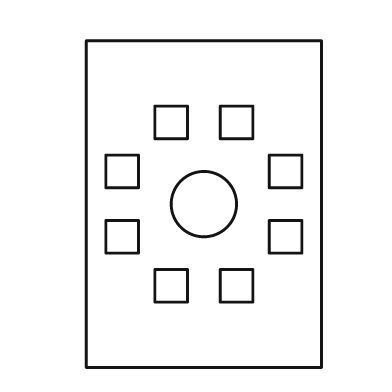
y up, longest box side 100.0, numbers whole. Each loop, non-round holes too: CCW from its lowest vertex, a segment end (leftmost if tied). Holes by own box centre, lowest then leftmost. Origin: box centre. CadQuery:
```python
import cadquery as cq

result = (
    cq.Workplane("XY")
    .moveTo(-36.0, -50.0)
    .lineTo(36.0, -50.0)
    .lineTo(36.0, 50.0)
    .lineTo(-36.0, 50.0)
    .close()
    .moveTo(-15.0, -30.0)
    .lineTo(-5.0, -30.0)
    .lineTo(-5.0, -20.0)
    .lineTo(-15.0, -20.0)
    .close()
    .moveTo(5.0, -30.0)
    .lineTo(15.0, -30.0)
    .lineTo(15.0, -20.0)
    .lineTo(5.0, -20.0)
    .close()
    .moveTo(-30.0, -15.0)
    .lineTo(-20.0, -15.0)
    .lineTo(-20.0, -5.0)
    .lineTo(-30.0, -5.0)
    .close()
    .moveTo(20.0, -15.0)
    .lineTo(30.0, -15.0)
    .lineTo(30.0, -5.0)
    .lineTo(20.0, -5.0)
    .close()
    .moveTo(0.0, 0.0)
    .circle(10.0)
    .moveTo(-30.0, 5.0)
    .lineTo(-20.0, 5.0)
    .lineTo(-20.0, 15.0)
    .lineTo(-30.0, 15.0)
    .close()
    .moveTo(20.0, 5.0)
    .lineTo(30.0, 5.0)
    .lineTo(30.0, 15.0)
    .lineTo(20.0, 15.0)
    .close()
    .moveTo(-15.0, 20.0)
    .lineTo(-5.0, 20.0)
    .lineTo(-5.0, 30.0)
    .lineTo(-15.0, 30.0)
    .close()
    .moveTo(5.0, 20.0)
    .lineTo(15.0, 20.0)
    .lineTo(15.0, 30.0)
    .lineTo(5.0, 30.0)
    .close()
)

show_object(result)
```